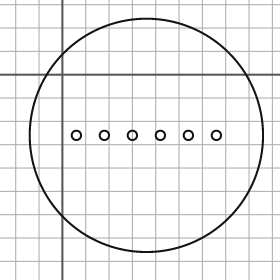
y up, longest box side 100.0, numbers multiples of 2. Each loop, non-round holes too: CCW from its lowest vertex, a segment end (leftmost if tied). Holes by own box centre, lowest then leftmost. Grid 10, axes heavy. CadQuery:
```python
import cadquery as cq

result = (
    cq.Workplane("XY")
    .moveTo(36.0, -26.0)
    .circle(50.0)
    .moveTo(6.0, -26.0)
    .circle(2.0)
    .moveTo(18.0, -26.0)
    .circle(2.0)
    .moveTo(30.0, -26.0)
    .circle(2.0)
    .moveTo(42.0, -26.0)
    .circle(2.0)
    .moveTo(54.0, -26.0)
    .circle(2.0)
    .moveTo(66.0, -26.0)
    .circle(2.0)
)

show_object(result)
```